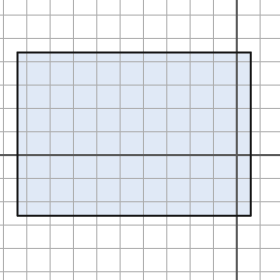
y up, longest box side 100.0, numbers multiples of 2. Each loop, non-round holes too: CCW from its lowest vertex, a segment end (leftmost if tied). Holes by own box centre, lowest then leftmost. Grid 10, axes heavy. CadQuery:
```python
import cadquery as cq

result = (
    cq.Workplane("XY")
    .moveTo(-94.0, -26.0)
    .lineTo(6.0, -26.0)
    .lineTo(6.0, 44.0)
    .lineTo(-94.0, 44.0)
    .close()
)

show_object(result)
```